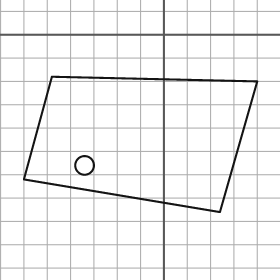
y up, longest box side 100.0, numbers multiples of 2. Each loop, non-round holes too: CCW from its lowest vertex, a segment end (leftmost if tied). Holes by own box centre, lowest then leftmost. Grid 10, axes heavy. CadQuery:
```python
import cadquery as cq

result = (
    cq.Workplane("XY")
    .moveTo(24.0, -76.0)
    .lineTo(40.0, -20.0)
    .lineTo(-48.0, -18.0)
    .lineTo(-60.0, -62.0)
    .close()
    .moveTo(-34.0, -56.0)
    .circle(4.0)
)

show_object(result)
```